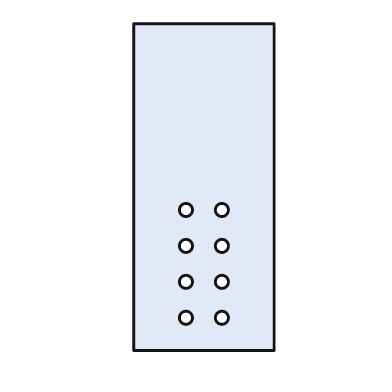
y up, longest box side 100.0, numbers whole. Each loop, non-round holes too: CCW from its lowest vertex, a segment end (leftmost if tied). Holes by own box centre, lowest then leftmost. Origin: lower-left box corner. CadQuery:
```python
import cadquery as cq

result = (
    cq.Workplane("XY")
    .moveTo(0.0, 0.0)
    .lineTo(43.0, 0.0)
    .lineTo(43.0, 100.0)
    .lineTo(0.0, 100.0)
    .close()
    .moveTo(16.0, 10.0)
    .circle(2.0)
    .moveTo(27.0, 10.0)
    .circle(2.0)
    .moveTo(16.0, 21.0)
    .circle(2.0)
    .moveTo(27.0, 21.0)
    .circle(2.0)
    .moveTo(16.0, 32.0)
    .circle(2.0)
    .moveTo(27.0, 32.0)
    .circle(2.0)
    .moveTo(16.0, 43.0)
    .circle(2.0)
    .moveTo(27.0, 43.0)
    .circle(2.0)
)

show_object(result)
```